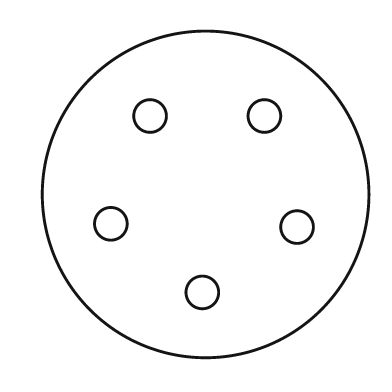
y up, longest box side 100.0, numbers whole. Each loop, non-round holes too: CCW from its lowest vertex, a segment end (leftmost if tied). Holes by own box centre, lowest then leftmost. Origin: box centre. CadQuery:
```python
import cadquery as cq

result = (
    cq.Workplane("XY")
    .moveTo(0.0, 0.0)
    .circle(50.0)
    .moveTo(-1.0, -30.0)
    .circle(5.0)
    .moveTo(28.0, -10.0)
    .circle(5.0)
    .moveTo(-29.0, -9.0)
    .circle(5.0)
    .moveTo(-17.0, 24.0)
    .circle(5.0)
    .moveTo(18.0, 24.0)
    .circle(5.0)
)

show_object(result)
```